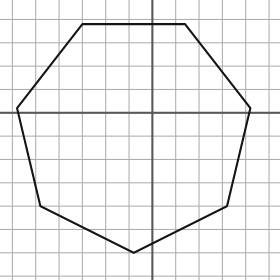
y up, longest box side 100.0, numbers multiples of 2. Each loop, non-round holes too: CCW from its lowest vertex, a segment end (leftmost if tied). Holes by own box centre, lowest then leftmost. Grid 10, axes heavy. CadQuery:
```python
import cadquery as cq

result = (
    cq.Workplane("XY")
    .moveTo(-8.0, -60.0)
    .lineTo(32.0, -40.0)
    .lineTo(42.0, 2.0)
    .lineTo(14.0, 38.0)
    .lineTo(-30.0, 38.0)
    .lineTo(-58.0, 2.0)
    .lineTo(-48.0, -40.0)
    .close()
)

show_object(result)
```